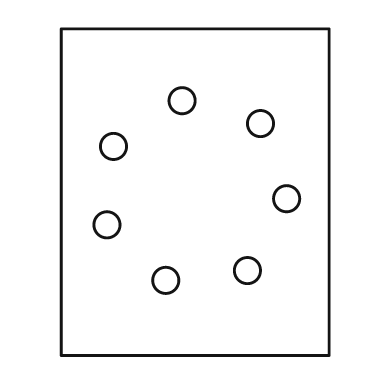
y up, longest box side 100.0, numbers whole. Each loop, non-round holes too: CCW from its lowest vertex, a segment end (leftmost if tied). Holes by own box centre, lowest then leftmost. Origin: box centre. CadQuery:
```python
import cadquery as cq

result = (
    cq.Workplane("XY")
    .moveTo(-41.0, -50.0)
    .lineTo(41.0, -50.0)
    .lineTo(41.0, 50.0)
    .lineTo(-41.0, 50.0)
    .close()
    .moveTo(-9.0, -27.0)
    .circle(4.0)
    .moveTo(16.0, -24.0)
    .circle(4.0)
    .moveTo(-27.0, -10.0)
    .circle(4.0)
    .moveTo(28.0, -2.0)
    .circle(4.0)
    .moveTo(-25.0, 14.0)
    .circle(4.0)
    .moveTo(20.0, 21.0)
    .circle(4.0)
    .moveTo(-4.0, 28.0)
    .circle(4.0)
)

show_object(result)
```